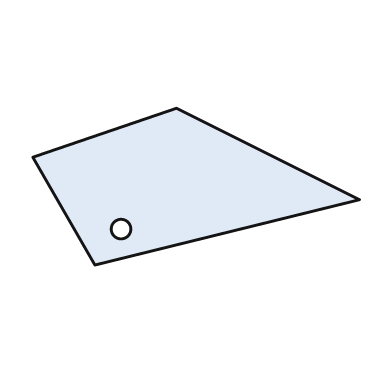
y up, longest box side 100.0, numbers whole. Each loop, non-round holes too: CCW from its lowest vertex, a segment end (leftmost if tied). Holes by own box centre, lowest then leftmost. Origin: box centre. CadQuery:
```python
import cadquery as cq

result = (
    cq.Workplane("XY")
    .moveTo(-31.0, -24.0)
    .lineTo(50.0, -4.0)
    .lineTo(-6.0, 24.0)
    .lineTo(-50.0, 9.0)
    .close()
    .moveTo(-23.0, -13.0)
    .circle(3.0)
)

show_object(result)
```